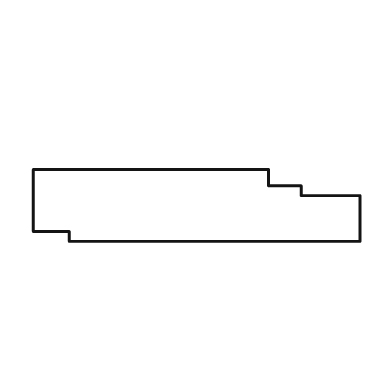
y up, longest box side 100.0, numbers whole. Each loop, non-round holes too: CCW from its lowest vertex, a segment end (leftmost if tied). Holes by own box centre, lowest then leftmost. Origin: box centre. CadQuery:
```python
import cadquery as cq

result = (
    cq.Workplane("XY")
    .moveTo(-39.0, -11.0)
    .lineTo(50.0, -11.0)
    .lineTo(50.0, 3.0)
    .lineTo(32.0, 3.0)
    .lineTo(32.0, 6.0)
    .lineTo(22.0, 6.0)
    .lineTo(22.0, 11.0)
    .lineTo(-50.0, 11.0)
    .lineTo(-50.0, -8.0)
    .lineTo(-39.0, -8.0)
    .close()
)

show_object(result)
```